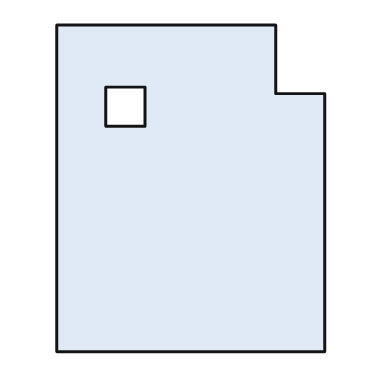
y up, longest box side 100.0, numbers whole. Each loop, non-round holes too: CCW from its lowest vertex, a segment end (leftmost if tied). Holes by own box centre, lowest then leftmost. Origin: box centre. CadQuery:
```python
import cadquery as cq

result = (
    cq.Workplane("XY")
    .moveTo(-41.0, -50.0)
    .lineTo(41.0, -50.0)
    .lineTo(41.0, 29.0)
    .lineTo(26.0, 29.0)
    .lineTo(26.0, 50.0)
    .lineTo(-41.0, 50.0)
    .close()
    .moveTo(-26.0, 19.0)
    .lineTo(-14.0, 19.0)
    .lineTo(-14.0, 31.0)
    .lineTo(-26.0, 31.0)
    .close()
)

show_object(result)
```